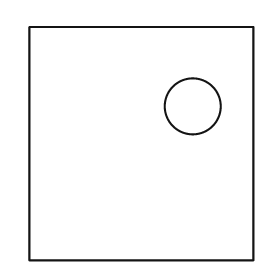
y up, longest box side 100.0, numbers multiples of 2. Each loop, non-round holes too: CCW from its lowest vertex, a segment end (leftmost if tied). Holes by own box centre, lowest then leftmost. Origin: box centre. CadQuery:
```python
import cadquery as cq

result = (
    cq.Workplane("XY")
    .moveTo(-48.0, -50.0)
    .lineTo(48.0, -50.0)
    .lineTo(48.0, 50.0)
    .lineTo(-48.0, 50.0)
    .close()
    .moveTo(22.0, 16.0)
    .circle(12.0)
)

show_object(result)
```